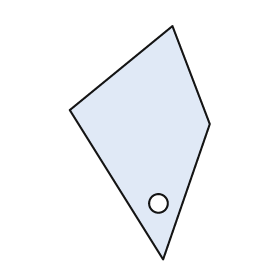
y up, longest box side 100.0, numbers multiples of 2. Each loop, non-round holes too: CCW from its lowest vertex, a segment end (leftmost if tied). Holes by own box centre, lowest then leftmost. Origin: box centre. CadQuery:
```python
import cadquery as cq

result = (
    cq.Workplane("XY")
    .moveTo(10.0, -50.0)
    .lineTo(30.0, 8.0)
    .lineTo(14.0, 50.0)
    .lineTo(-30.0, 14.0)
    .close()
    .moveTo(8.0, -26.0)
    .circle(4.0)
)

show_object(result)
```